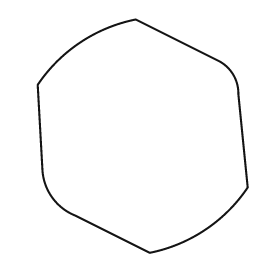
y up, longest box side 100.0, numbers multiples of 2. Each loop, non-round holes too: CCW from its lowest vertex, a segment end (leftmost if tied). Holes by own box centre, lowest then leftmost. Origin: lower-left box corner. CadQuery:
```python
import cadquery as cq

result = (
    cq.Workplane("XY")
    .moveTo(48.0, 0.0)
    .threePointArc((72.0, 10.0), (90.0, 28.0))
    .lineTo(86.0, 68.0)
    .threePointArc((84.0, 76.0), (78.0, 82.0))
    .lineTo(42.0, 100.0)
    .threePointArc((18.0, 90.0), (0.0, 72.0))
    .lineTo(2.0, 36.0)
    .threePointArc((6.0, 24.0), (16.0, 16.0))
    .close()
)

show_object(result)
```